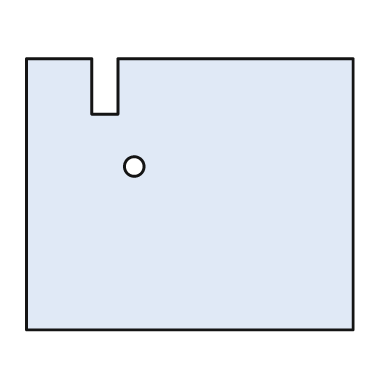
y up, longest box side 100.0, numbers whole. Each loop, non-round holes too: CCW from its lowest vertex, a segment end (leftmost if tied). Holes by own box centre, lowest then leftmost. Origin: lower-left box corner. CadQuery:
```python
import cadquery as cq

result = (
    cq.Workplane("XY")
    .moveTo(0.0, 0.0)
    .lineTo(100.0, 0.0)
    .lineTo(100.0, 83.0)
    .lineTo(28.0, 83.0)
    .lineTo(28.0, 66.0)
    .lineTo(20.0, 66.0)
    .lineTo(20.0, 83.0)
    .lineTo(0.0, 83.0)
    .close()
    .moveTo(33.0, 50.0)
    .circle(3.0)
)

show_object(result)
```